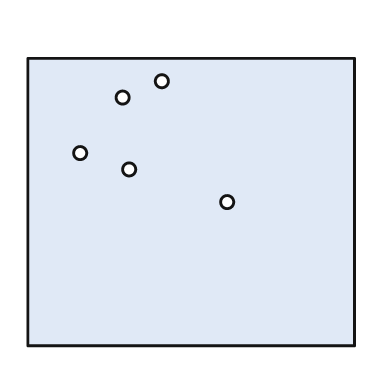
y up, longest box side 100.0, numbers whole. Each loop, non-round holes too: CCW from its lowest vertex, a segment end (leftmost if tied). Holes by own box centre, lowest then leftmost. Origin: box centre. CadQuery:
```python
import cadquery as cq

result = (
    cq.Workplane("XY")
    .moveTo(-50.0, -44.0)
    .lineTo(50.0, -44.0)
    .lineTo(50.0, 44.0)
    .lineTo(-50.0, 44.0)
    .close()
    .moveTo(11.0, 0.0)
    .circle(2.0)
    .moveTo(-19.0, 10.0)
    .circle(2.0)
    .moveTo(-34.0, 15.0)
    .circle(2.0)
    .moveTo(-21.0, 32.0)
    .circle(2.0)
    .moveTo(-9.0, 37.0)
    .circle(2.0)
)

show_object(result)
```